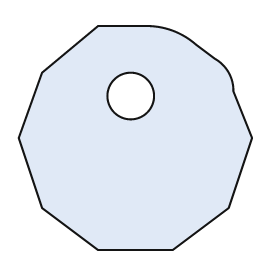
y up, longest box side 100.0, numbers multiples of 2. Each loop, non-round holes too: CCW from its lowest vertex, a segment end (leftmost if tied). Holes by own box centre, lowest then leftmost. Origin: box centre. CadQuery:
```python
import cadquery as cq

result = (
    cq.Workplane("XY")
    .moveTo(-16.0, -48.0)
    .lineTo(16.0, -48.0)
    .lineTo(40.0, -30.0)
    .lineTo(50.0, 0.0)
    .lineTo(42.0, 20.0)
    .threePointArc((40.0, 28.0), (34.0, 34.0))
    .lineTo(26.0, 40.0)
    .threePointArc((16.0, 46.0), (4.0, 48.0))
    .lineTo(-16.0, 48.0)
    .lineTo(-40.0, 28.0)
    .lineTo(-50.0, 0.0)
    .lineTo(-40.0, -30.0)
    .close()
    .moveTo(-2.0, 18.0)
    .circle(10.0)
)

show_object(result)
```